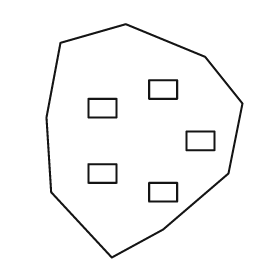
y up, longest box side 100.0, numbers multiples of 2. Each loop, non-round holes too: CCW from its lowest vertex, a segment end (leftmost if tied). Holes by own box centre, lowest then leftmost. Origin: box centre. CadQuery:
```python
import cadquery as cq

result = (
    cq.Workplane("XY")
    .moveTo(-14.0, -50.0)
    .lineTo(8.0, -38.0)
    .lineTo(36.0, -14.0)
    .lineTo(42.0, 16.0)
    .lineTo(26.0, 36.0)
    .lineTo(-8.0, 50.0)
    .lineTo(-36.0, 42.0)
    .lineTo(-42.0, 10.0)
    .lineTo(-40.0, -22.0)
    .close()
    .moveTo(2.0, -26.0)
    .lineTo(14.0, -26.0)
    .lineTo(14.0, -18.0)
    .lineTo(2.0, -18.0)
    .close()
    .moveTo(-24.0, -18.0)
    .lineTo(-12.0, -18.0)
    .lineTo(-12.0, -10.0)
    .lineTo(-24.0, -10.0)
    .close()
    .moveTo(18.0, -4.0)
    .lineTo(30.0, -4.0)
    .lineTo(30.0, 4.0)
    .lineTo(18.0, 4.0)
    .close()
    .moveTo(-24.0, 10.0)
    .lineTo(-12.0, 10.0)
    .lineTo(-12.0, 18.0)
    .lineTo(-24.0, 18.0)
    .close()
    .moveTo(2.0, 18.0)
    .lineTo(14.0, 18.0)
    .lineTo(14.0, 26.0)
    .lineTo(2.0, 26.0)
    .close()
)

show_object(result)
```